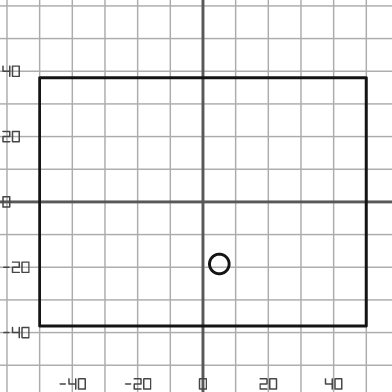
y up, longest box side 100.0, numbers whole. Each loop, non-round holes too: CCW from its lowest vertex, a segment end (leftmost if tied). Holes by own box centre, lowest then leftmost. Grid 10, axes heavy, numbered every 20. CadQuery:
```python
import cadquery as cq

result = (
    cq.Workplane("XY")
    .moveTo(-50.0, -38.0)
    .lineTo(50.0, -38.0)
    .lineTo(50.0, 38.0)
    .lineTo(-50.0, 38.0)
    .close()
    .moveTo(5.0, -19.0)
    .circle(3.0)
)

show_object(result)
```